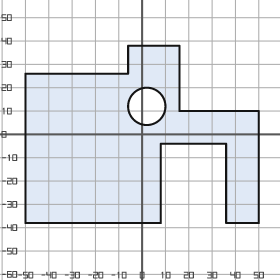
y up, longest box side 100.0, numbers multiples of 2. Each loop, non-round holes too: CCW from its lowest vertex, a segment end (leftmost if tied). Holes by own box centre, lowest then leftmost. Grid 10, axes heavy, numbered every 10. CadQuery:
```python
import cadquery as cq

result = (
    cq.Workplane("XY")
    .moveTo(-50.0, -38.0)
    .lineTo(8.0, -38.0)
    .lineTo(8.0, -4.0)
    .lineTo(36.0, -4.0)
    .lineTo(36.0, -38.0)
    .lineTo(50.0, -38.0)
    .lineTo(50.0, 10.0)
    .lineTo(16.0, 10.0)
    .lineTo(16.0, 38.0)
    .lineTo(-6.0, 38.0)
    .lineTo(-6.0, 26.0)
    .lineTo(-50.0, 26.0)
    .close()
    .moveTo(2.0, 12.0)
    .circle(8.0)
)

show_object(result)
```